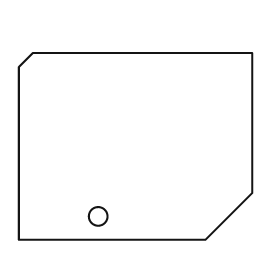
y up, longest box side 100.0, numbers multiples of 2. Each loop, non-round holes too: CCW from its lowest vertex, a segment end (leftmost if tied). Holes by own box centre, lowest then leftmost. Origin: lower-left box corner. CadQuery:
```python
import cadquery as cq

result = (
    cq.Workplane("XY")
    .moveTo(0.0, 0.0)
    .lineTo(80.0, 0.0)
    .lineTo(100.0, 20.0)
    .lineTo(100.0, 80.0)
    .lineTo(6.0, 80.0)
    .lineTo(0.0, 74.0)
    .close()
    .moveTo(34.0, 10.0)
    .circle(4.0)
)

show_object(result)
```